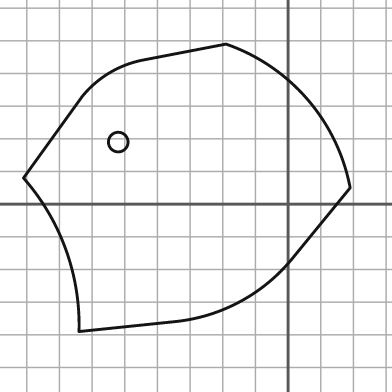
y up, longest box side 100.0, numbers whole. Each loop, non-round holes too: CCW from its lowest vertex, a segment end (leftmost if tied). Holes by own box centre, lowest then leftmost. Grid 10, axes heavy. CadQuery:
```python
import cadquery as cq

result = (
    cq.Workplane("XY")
    .moveTo(-64.0, -39.0)
    .lineTo(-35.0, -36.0)
    .threePointArc((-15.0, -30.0), (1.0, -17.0))
    .lineTo(19.0, 5.0)
    .threePointArc((6.0, 32.0), (-19.0, 49.0))
    .lineTo(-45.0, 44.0)
    .threePointArc((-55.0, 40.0), (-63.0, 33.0))
    .lineTo(-81.0, 8.0)
    .threePointArc((-68.0, -14.0), (-64.0, -39.0))
    .close()
    .moveTo(-52.0, 19.0)
    .circle(3.0)
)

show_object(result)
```